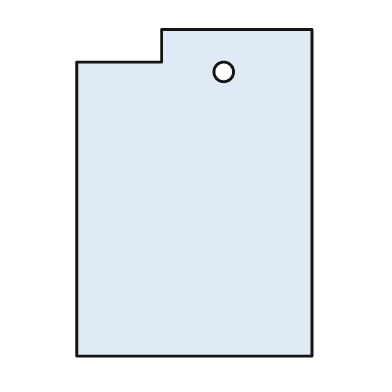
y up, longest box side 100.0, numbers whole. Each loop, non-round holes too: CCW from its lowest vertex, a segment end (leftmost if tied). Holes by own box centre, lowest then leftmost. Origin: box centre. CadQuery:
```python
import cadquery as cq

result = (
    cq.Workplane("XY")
    .moveTo(-36.0, -50.0)
    .lineTo(36.0, -50.0)
    .lineTo(36.0, 50.0)
    .lineTo(-10.0, 50.0)
    .lineTo(-10.0, 40.0)
    .lineTo(-36.0, 40.0)
    .close()
    .moveTo(9.0, 37.0)
    .circle(3.0)
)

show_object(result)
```